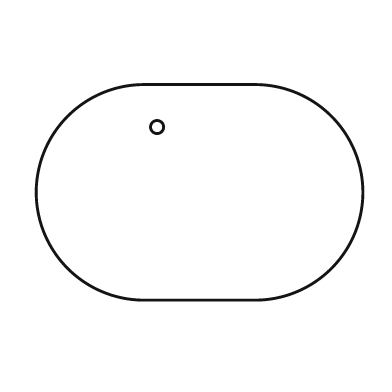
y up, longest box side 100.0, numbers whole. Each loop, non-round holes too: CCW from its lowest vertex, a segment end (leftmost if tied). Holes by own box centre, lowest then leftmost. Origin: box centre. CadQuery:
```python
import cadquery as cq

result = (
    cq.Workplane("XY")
    .moveTo(-17.0, -33.0)
    .lineTo(17.0, -33.0)
    .threePointArc((50.0, 0.0), (17.0, 33.0))
    .lineTo(-17.0, 33.0)
    .threePointArc((-50.0, 0.0), (-17.0, -33.0))
    .close()
    .moveTo(-13.0, 20.0)
    .circle(2.0)
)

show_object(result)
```